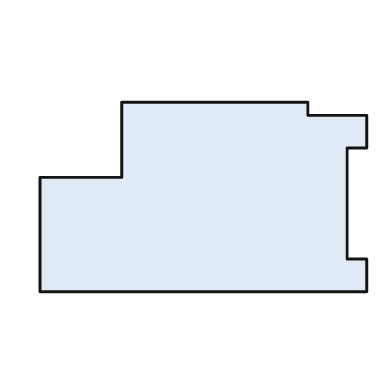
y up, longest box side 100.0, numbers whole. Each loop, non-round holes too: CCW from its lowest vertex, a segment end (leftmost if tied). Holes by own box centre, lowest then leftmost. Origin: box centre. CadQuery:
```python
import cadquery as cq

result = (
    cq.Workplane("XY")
    .moveTo(-50.0, -29.0)
    .lineTo(50.0, -29.0)
    .lineTo(50.0, -19.0)
    .lineTo(44.0, -19.0)
    .lineTo(44.0, 15.0)
    .lineTo(50.0, 15.0)
    .lineTo(50.0, 25.0)
    .lineTo(32.0, 25.0)
    .lineTo(32.0, 29.0)
    .lineTo(-25.0, 29.0)
    .lineTo(-25.0, 6.0)
    .lineTo(-50.0, 6.0)
    .close()
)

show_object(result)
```